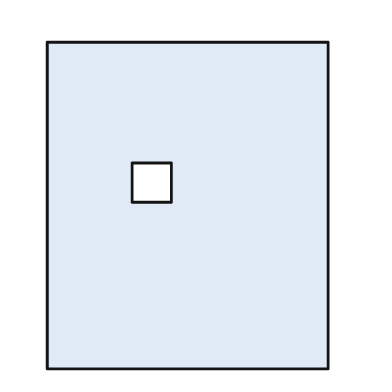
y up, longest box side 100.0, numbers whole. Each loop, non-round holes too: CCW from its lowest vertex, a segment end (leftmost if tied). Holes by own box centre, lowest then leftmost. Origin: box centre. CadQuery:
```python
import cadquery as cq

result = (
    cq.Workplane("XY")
    .moveTo(-43.0, -50.0)
    .lineTo(43.0, -50.0)
    .lineTo(43.0, 50.0)
    .lineTo(-43.0, 50.0)
    .close()
    .moveTo(-17.0, 1.0)
    .lineTo(-5.0, 1.0)
    .lineTo(-5.0, 13.0)
    .lineTo(-17.0, 13.0)
    .close()
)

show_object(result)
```